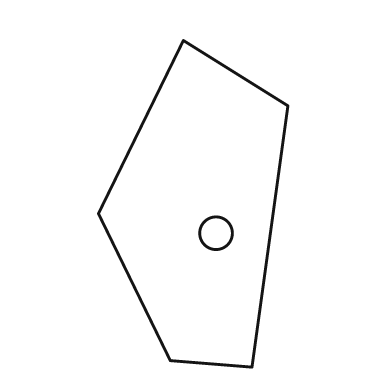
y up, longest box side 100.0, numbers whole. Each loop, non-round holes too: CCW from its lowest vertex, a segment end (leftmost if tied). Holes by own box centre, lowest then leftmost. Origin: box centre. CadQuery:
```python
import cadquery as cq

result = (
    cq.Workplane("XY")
    .moveTo(18.0, -50.0)
    .lineTo(29.0, 30.0)
    .lineTo(-3.0, 50.0)
    .lineTo(-29.0, -3.0)
    .lineTo(-7.0, -48.0)
    .close()
    .moveTo(7.0, -9.0)
    .circle(5.0)
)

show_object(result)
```